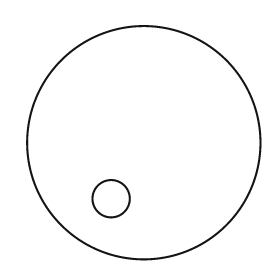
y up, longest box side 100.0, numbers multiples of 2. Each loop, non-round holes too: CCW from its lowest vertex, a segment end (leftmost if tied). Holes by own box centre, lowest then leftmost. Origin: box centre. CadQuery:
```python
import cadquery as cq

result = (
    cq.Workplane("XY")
    .moveTo(0.0, 0.0)
    .circle(50.0)
    .moveTo(-14.0, -24.0)
    .circle(8.0)
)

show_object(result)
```